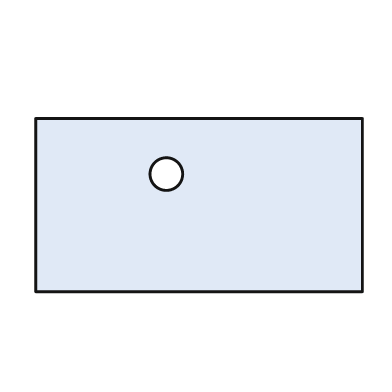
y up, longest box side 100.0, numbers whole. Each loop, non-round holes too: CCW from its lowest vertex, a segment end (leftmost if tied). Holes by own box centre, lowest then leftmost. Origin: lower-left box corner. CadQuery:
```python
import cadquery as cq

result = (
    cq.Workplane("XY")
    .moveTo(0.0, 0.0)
    .lineTo(100.0, 0.0)
    .lineTo(100.0, 53.0)
    .lineTo(0.0, 53.0)
    .close()
    .moveTo(40.0, 36.0)
    .circle(5.0)
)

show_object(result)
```